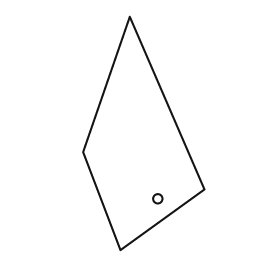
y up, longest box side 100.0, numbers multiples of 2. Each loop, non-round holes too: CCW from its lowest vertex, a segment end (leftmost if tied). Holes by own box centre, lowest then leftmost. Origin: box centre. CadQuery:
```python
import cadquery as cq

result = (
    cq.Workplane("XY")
    .moveTo(-10.0, -50.0)
    .lineTo(26.0, -24.0)
    .lineTo(-6.0, 50.0)
    .lineTo(-26.0, -8.0)
    .close()
    .moveTo(6.0, -28.0)
    .circle(2.0)
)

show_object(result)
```